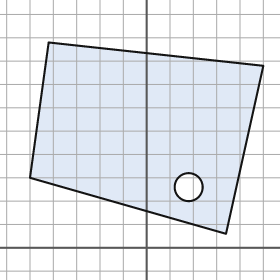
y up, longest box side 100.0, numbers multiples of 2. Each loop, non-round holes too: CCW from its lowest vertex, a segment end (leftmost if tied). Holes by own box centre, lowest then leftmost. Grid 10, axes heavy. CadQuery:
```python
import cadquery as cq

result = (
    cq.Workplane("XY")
    .moveTo(34.0, 6.0)
    .lineTo(50.0, 78.0)
    .lineTo(-42.0, 88.0)
    .lineTo(-50.0, 30.0)
    .close()
    .moveTo(18.0, 26.0)
    .circle(6.0)
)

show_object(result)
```